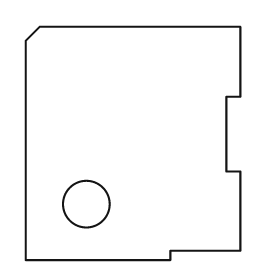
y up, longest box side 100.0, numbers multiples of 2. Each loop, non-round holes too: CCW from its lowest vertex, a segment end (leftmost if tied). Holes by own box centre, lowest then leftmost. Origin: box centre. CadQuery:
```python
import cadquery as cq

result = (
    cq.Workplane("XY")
    .moveTo(-46.0, -50.0)
    .lineTo(16.0, -50.0)
    .lineTo(16.0, -46.0)
    .lineTo(46.0, -46.0)
    .lineTo(46.0, -12.0)
    .lineTo(40.0, -12.0)
    .lineTo(40.0, 20.0)
    .lineTo(46.0, 20.0)
    .lineTo(46.0, 50.0)
    .lineTo(-40.0, 50.0)
    .lineTo(-46.0, 44.0)
    .close()
    .moveTo(-20.0, -26.0)
    .circle(10.0)
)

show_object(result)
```